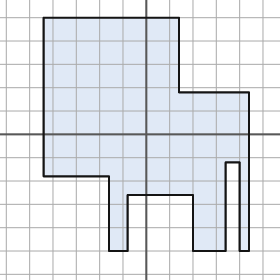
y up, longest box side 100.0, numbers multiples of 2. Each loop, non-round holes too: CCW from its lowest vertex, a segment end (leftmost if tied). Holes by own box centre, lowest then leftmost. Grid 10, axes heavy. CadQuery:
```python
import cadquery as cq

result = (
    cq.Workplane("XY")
    .moveTo(-16.0, -50.0)
    .lineTo(-8.0, -50.0)
    .lineTo(-8.0, -26.0)
    .lineTo(20.0, -26.0)
    .lineTo(20.0, -50.0)
    .lineTo(34.0, -50.0)
    .lineTo(34.0, -12.0)
    .lineTo(40.0, -12.0)
    .lineTo(40.0, -50.0)
    .lineTo(44.0, -50.0)
    .lineTo(44.0, 18.0)
    .lineTo(14.0, 18.0)
    .lineTo(14.0, 50.0)
    .lineTo(-44.0, 50.0)
    .lineTo(-44.0, -18.0)
    .lineTo(-16.0, -18.0)
    .close()
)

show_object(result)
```